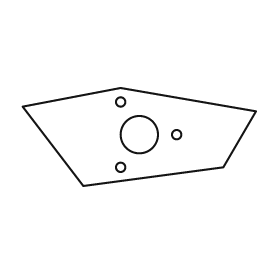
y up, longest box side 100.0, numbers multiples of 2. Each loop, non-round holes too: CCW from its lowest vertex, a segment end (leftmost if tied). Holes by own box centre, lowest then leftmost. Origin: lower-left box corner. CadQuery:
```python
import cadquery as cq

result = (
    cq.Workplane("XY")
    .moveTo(26.0, 0.0)
    .lineTo(86.0, 8.0)
    .lineTo(100.0, 32.0)
    .lineTo(42.0, 42.0)
    .lineTo(0.0, 34.0)
    .close()
    .moveTo(42.0, 8.0)
    .circle(2.0)
    .moveTo(50.0, 22.0)
    .circle(8.0)
    .moveTo(66.0, 22.0)
    .circle(2.0)
    .moveTo(42.0, 36.0)
    .circle(2.0)
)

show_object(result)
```